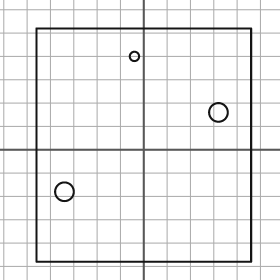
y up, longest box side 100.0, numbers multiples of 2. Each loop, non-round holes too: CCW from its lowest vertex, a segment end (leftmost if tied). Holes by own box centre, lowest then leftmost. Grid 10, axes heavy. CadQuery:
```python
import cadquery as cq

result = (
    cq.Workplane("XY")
    .moveTo(-46.0, -48.0)
    .lineTo(46.0, -48.0)
    .lineTo(46.0, 52.0)
    .lineTo(-46.0, 52.0)
    .close()
    .moveTo(-34.0, -18.0)
    .circle(4.0)
    .moveTo(32.0, 16.0)
    .circle(4.0)
    .moveTo(-4.0, 40.0)
    .circle(2.0)
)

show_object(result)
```